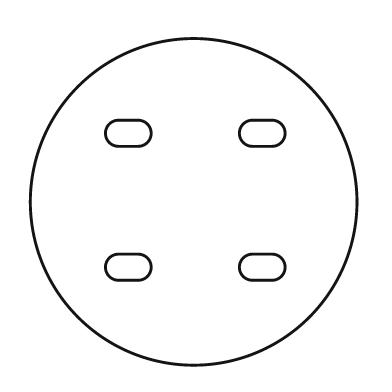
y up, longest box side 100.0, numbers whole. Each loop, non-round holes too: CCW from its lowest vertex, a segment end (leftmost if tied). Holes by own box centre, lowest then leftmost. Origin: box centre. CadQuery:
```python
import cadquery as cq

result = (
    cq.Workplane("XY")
    .moveTo(0.0, 0.0)
    .circle(50.0)
    .moveTo(-23.0, -24.0)
    .lineTo(-17.0, -24.0)
    .threePointArc((-13.0, -20.0), (-17.0, -16.0))
    .lineTo(-23.0, -16.0)
    .threePointArc((-27.0, -20.0), (-23.0, -24.0))
    .close()
    .moveTo(18.0, -24.0)
    .lineTo(24.0, -24.0)
    .threePointArc((28.0, -20.0), (24.0, -16.0))
    .lineTo(18.0, -16.0)
    .threePointArc((14.0, -20.0), (18.0, -24.0))
    .close()
    .moveTo(-23.0, 17.0)
    .lineTo(-17.0, 17.0)
    .threePointArc((-13.0, 21.0), (-17.0, 25.0))
    .lineTo(-23.0, 25.0)
    .threePointArc((-27.0, 21.0), (-23.0, 17.0))
    .close()
    .moveTo(18.0, 17.0)
    .lineTo(24.0, 17.0)
    .threePointArc((28.0, 21.0), (24.0, 25.0))
    .lineTo(18.0, 25.0)
    .threePointArc((14.0, 21.0), (18.0, 17.0))
    .close()
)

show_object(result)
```